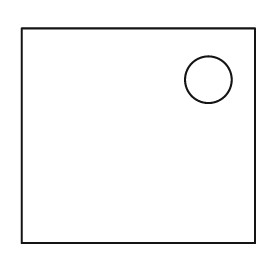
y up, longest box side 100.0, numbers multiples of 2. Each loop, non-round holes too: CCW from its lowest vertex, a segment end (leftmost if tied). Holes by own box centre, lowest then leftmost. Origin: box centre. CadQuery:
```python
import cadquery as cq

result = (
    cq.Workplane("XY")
    .moveTo(-50.0, -46.0)
    .lineTo(50.0, -46.0)
    .lineTo(50.0, 46.0)
    .lineTo(-50.0, 46.0)
    .close()
    .moveTo(30.0, 24.0)
    .circle(10.0)
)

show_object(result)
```